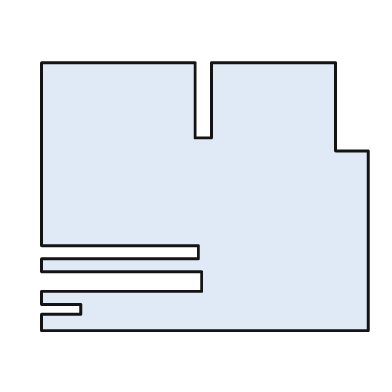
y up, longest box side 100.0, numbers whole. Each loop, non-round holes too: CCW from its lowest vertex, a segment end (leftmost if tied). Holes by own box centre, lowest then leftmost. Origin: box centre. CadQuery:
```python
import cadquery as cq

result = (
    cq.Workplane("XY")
    .moveTo(-50.0, -41.0)
    .lineTo(50.0, -41.0)
    .lineTo(50.0, 14.0)
    .lineTo(40.0, 14.0)
    .lineTo(40.0, 41.0)
    .lineTo(2.0, 41.0)
    .lineTo(2.0, 18.0)
    .lineTo(-3.0, 18.0)
    .lineTo(-3.0, 41.0)
    .lineTo(-50.0, 41.0)
    .lineTo(-50.0, -15.0)
    .lineTo(-2.0, -15.0)
    .lineTo(-2.0, -19.0)
    .lineTo(-50.0, -19.0)
    .lineTo(-50.0, -23.0)
    .lineTo(-1.0, -23.0)
    .lineTo(-1.0, -29.0)
    .lineTo(-50.0, -29.0)
    .lineTo(-50.0, -33.0)
    .lineTo(-38.0, -33.0)
    .lineTo(-38.0, -36.0)
    .lineTo(-50.0, -36.0)
    .close()
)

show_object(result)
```